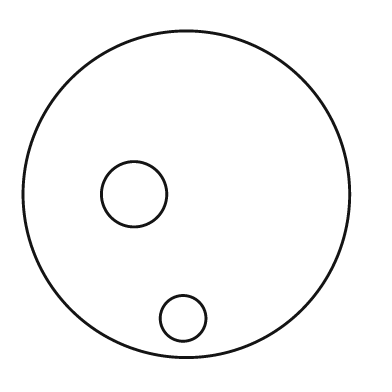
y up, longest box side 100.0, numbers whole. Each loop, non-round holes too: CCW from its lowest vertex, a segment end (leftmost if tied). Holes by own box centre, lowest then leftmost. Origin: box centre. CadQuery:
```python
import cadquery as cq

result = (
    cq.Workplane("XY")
    .moveTo(0.0, 0.0)
    .circle(50.0)
    .moveTo(-1.0, -38.0)
    .circle(7.0)
    .moveTo(-16.0, 0.0)
    .circle(10.0)
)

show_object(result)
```